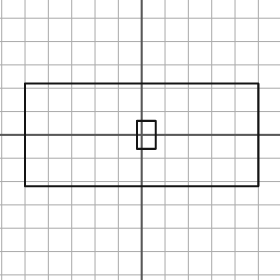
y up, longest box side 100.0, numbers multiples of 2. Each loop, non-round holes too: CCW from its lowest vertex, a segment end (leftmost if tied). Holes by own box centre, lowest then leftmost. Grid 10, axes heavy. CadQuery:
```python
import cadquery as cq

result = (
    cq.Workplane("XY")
    .moveTo(-50.0, -22.0)
    .lineTo(50.0, -22.0)
    .lineTo(50.0, 22.0)
    .lineTo(-50.0, 22.0)
    .close()
    .moveTo(-2.0, -6.0)
    .lineTo(6.0, -6.0)
    .lineTo(6.0, 6.0)
    .lineTo(-2.0, 6.0)
    .close()
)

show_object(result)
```